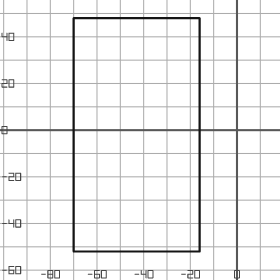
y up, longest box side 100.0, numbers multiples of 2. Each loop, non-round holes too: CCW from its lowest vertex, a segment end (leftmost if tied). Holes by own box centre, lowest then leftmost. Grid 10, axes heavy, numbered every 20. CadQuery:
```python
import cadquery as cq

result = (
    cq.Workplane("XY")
    .moveTo(-70.0, -52.0)
    .lineTo(-16.0, -52.0)
    .lineTo(-16.0, 48.0)
    .lineTo(-70.0, 48.0)
    .close()
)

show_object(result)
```